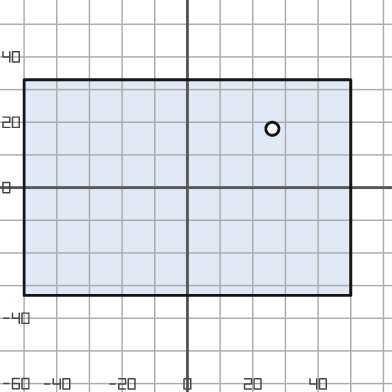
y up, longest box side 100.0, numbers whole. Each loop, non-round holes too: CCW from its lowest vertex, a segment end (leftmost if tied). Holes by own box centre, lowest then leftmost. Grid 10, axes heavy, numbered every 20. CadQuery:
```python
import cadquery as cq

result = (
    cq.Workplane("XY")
    .moveTo(-50.0, -33.0)
    .lineTo(50.0, -33.0)
    .lineTo(50.0, 33.0)
    .lineTo(-50.0, 33.0)
    .close()
    .moveTo(26.0, 18.0)
    .circle(2.0)
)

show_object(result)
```